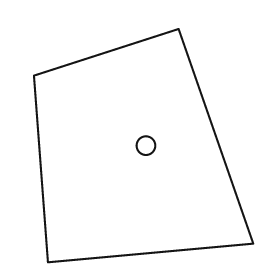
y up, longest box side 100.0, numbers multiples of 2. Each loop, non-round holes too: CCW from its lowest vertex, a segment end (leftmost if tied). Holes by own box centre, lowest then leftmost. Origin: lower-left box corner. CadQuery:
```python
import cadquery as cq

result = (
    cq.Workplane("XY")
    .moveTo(6.0, 0.0)
    .lineTo(94.0, 8.0)
    .lineTo(62.0, 100.0)
    .lineTo(0.0, 80.0)
    .close()
    .moveTo(48.0, 50.0)
    .circle(4.0)
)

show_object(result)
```